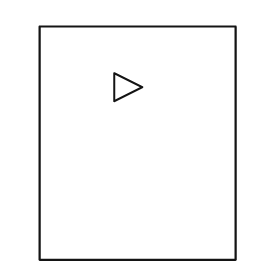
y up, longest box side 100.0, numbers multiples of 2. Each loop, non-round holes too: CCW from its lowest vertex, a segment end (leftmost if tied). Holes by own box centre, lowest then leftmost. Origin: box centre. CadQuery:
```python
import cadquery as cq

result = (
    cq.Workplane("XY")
    .moveTo(-42.0, -50.0)
    .lineTo(42.0, -50.0)
    .lineTo(42.0, 50.0)
    .lineTo(-42.0, 50.0)
    .close()
    .moveTo(-10.0, 18.0)
    .lineTo(2.0, 24.0)
    .lineTo(-10.0, 30.0)
    .close()
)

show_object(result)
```